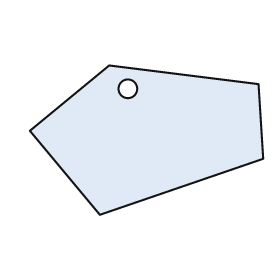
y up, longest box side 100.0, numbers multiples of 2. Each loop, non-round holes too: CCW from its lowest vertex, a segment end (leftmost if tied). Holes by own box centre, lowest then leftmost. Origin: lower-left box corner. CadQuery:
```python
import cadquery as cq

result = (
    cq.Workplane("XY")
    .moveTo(30.0, 0.0)
    .lineTo(100.0, 24.0)
    .lineTo(98.0, 56.0)
    .lineTo(34.0, 64.0)
    .lineTo(0.0, 36.0)
    .close()
    .moveTo(42.0, 54.0)
    .circle(4.0)
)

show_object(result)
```